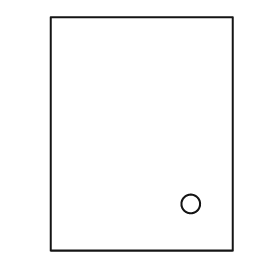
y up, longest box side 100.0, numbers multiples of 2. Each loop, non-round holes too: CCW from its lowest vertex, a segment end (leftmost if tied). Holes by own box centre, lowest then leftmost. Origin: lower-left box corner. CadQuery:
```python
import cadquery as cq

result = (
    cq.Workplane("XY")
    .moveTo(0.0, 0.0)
    .lineTo(78.0, 0.0)
    .lineTo(78.0, 100.0)
    .lineTo(0.0, 100.0)
    .close()
    .moveTo(60.0, 20.0)
    .circle(4.0)
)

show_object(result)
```